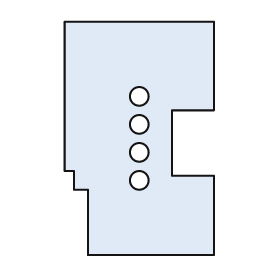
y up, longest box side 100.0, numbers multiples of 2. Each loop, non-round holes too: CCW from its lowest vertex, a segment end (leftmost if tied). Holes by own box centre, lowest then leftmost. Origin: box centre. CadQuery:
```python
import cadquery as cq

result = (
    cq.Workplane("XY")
    .moveTo(-22.0, -50.0)
    .lineTo(32.0, -50.0)
    .lineTo(32.0, -16.0)
    .lineTo(14.0, -16.0)
    .lineTo(14.0, 12.0)
    .lineTo(32.0, 12.0)
    .lineTo(32.0, 50.0)
    .lineTo(-32.0, 50.0)
    .lineTo(-32.0, -14.0)
    .lineTo(-28.0, -14.0)
    .lineTo(-28.0, -22.0)
    .lineTo(-22.0, -22.0)
    .close()
    .moveTo(0.0, -18.0)
    .circle(4.0)
    .moveTo(0.0, -6.0)
    .circle(4.0)
    .moveTo(0.0, 6.0)
    .circle(4.0)
    .moveTo(0.0, 18.0)
    .circle(4.0)
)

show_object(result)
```